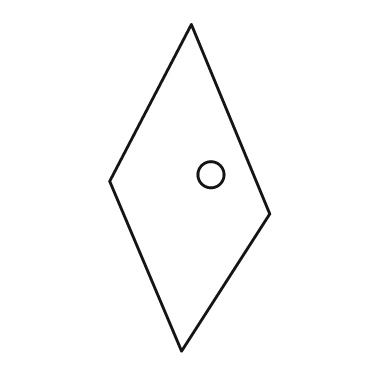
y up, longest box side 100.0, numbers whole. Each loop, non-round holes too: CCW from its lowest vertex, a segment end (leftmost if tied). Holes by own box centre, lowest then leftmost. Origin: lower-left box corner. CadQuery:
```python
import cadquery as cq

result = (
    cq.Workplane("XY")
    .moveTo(22.0, 0.0)
    .lineTo(49.0, 42.0)
    .lineTo(25.0, 100.0)
    .lineTo(0.0, 52.0)
    .close()
    .moveTo(31.0, 54.0)
    .circle(4.0)
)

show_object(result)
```